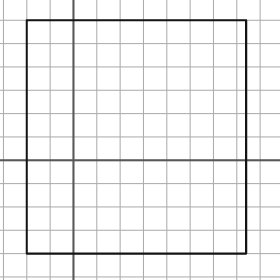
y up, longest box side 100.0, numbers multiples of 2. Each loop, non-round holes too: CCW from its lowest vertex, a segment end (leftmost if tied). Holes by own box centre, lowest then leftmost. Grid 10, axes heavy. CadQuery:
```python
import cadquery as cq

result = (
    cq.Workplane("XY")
    .moveTo(-20.0, -40.0)
    .lineTo(74.0, -40.0)
    .lineTo(74.0, 60.0)
    .lineTo(-20.0, 60.0)
    .close()
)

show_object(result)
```